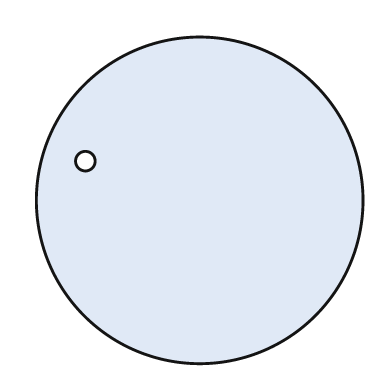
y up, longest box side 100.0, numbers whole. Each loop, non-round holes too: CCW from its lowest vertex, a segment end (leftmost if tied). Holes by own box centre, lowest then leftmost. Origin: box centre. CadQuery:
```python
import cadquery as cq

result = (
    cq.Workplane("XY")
    .moveTo(0.0, 0.0)
    .circle(50.0)
    .moveTo(-35.0, 12.0)
    .circle(3.0)
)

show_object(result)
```